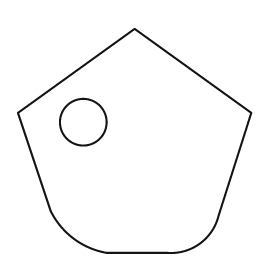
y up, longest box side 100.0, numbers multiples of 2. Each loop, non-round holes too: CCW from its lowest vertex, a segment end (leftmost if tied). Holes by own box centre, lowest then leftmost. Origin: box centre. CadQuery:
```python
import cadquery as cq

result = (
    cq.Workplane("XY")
    .moveTo(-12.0, -48.0)
    .lineTo(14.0, -48.0)
    .threePointArc((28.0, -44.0), (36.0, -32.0))
    .lineTo(50.0, 12.0)
    .lineTo(0.0, 48.0)
    .lineTo(-50.0, 12.0)
    .lineTo(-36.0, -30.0)
    .threePointArc((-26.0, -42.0), (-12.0, -48.0))
    .close()
    .moveTo(-22.0, 8.0)
    .circle(10.0)
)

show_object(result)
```